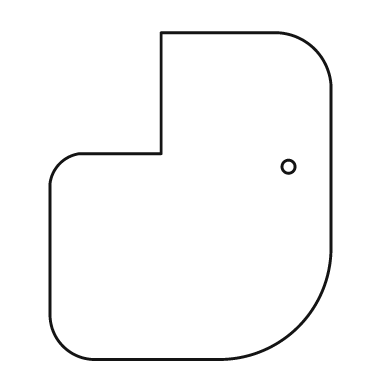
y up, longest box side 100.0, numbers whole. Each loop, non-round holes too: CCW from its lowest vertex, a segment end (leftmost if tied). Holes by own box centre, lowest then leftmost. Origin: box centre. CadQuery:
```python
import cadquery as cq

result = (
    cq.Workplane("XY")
    .moveTo(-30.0, -50.0)
    .lineTo(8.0, -50.0)
    .threePointArc((33.0, -40.0), (43.0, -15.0))
    .lineTo(43.0, 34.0)
    .threePointArc((38.0, 45.0), (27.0, 50.0))
    .lineTo(-9.0, 50.0)
    .lineTo(-9.0, 13.0)
    .lineTo(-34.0, 13.0)
    .threePointArc((-40.0, 10.0), (-43.0, 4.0))
    .lineTo(-43.0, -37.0)
    .threePointArc((-39.0, -46.0), (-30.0, -50.0))
    .close()
    .moveTo(30.0, 9.0)
    .circle(2.0)
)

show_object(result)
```